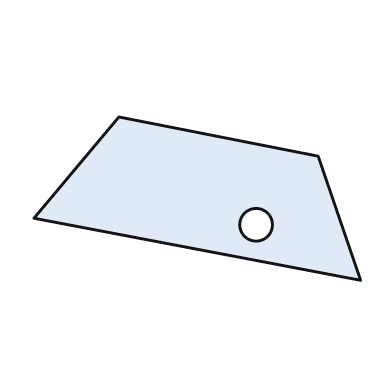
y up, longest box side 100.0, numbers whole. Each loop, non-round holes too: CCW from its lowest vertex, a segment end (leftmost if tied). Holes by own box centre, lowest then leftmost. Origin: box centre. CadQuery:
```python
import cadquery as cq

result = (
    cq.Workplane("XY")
    .moveTo(50.0, -25.0)
    .lineTo(37.0, 13.0)
    .lineTo(-24.0, 25.0)
    .lineTo(-50.0, -6.0)
    .close()
    .moveTo(18.0, -8.0)
    .circle(5.0)
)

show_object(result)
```